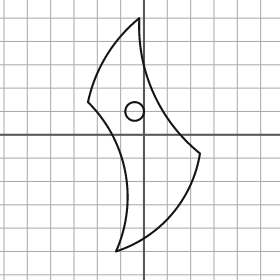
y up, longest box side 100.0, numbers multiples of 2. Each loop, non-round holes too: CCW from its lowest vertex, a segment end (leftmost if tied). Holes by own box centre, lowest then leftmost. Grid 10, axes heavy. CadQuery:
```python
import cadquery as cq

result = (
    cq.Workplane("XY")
    .moveTo(-12.0, -50.0)
    .threePointArc((12.0, -34.0), (24.0, -8.0))
    .threePointArc((4.0, 18.0), (-2.0, 50.0))
    .threePointArc((-16.0, 34.0), (-24.0, 14.0))
    .threePointArc((-8.0, -16.0), (-12.0, -50.0))
    .close()
    .moveTo(-4.0, 10.0)
    .circle(4.0)
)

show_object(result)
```